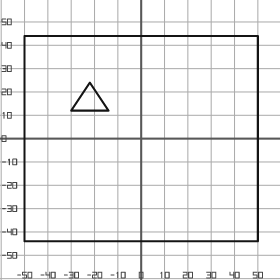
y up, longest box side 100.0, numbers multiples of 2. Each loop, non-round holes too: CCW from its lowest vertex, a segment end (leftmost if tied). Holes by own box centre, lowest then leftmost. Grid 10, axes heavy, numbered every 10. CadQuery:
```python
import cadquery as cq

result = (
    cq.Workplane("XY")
    .moveTo(-50.0, -44.0)
    .lineTo(50.0, -44.0)
    .lineTo(50.0, 44.0)
    .lineTo(-50.0, 44.0)
    .close()
    .moveTo(-30.0, 12.0)
    .lineTo(-14.0, 12.0)
    .lineTo(-22.0, 24.0)
    .close()
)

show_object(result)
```